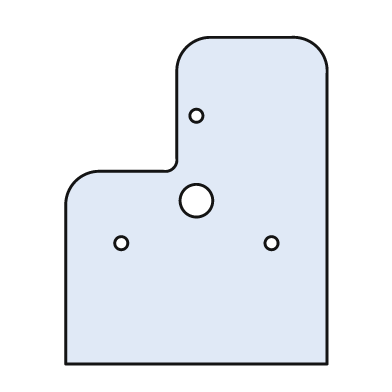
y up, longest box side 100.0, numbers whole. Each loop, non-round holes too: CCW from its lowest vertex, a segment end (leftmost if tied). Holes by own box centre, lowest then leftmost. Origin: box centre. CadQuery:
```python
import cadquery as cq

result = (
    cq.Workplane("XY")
    .moveTo(-40.0, -50.0)
    .lineTo(40.0, -50.0)
    .lineTo(40.0, 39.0)
    .threePointArc((37.0, 47.0), (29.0, 50.0))
    .lineTo(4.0, 50.0)
    .threePointArc((-3.0, 47.0), (-6.0, 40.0))
    .lineTo(-6.0, 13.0)
    .threePointArc((-7.0, 10.0), (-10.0, 9.0))
    .lineTo(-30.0, 9.0)
    .threePointArc((-37.0, 6.0), (-40.0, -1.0))
    .close()
    .moveTo(-23.0, -13.0)
    .circle(2.0)
    .moveTo(23.0, -13.0)
    .circle(2.0)
    .moveTo(0.0, 0.0)
    .circle(5.0)
    .moveTo(0.0, 26.0)
    .circle(2.0)
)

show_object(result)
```